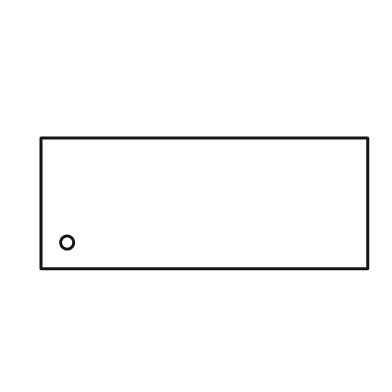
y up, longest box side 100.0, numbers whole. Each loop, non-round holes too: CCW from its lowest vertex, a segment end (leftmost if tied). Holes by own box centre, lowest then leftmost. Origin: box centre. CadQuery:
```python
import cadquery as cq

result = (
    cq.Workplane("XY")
    .moveTo(-50.0, -20.0)
    .lineTo(50.0, -20.0)
    .lineTo(50.0, 20.0)
    .lineTo(-50.0, 20.0)
    .close()
    .moveTo(-42.0, -12.0)
    .circle(2.0)
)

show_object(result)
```